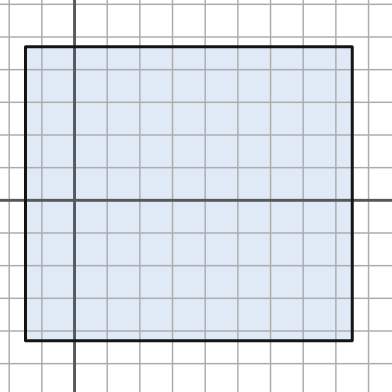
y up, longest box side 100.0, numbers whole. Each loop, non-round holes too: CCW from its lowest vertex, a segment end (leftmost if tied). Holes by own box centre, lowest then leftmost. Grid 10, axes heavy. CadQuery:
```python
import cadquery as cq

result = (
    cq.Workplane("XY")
    .moveTo(-15.0, -43.0)
    .lineTo(85.0, -43.0)
    .lineTo(85.0, 47.0)
    .lineTo(-15.0, 47.0)
    .close()
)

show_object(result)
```